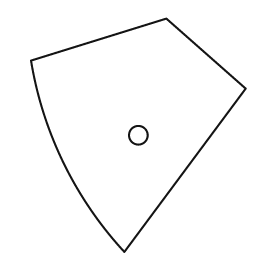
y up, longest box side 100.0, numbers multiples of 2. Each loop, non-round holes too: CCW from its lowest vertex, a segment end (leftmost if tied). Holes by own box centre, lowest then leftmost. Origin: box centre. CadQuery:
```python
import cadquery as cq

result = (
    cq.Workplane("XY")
    .moveTo(-6.0, -50.0)
    .lineTo(46.0, 20.0)
    .lineTo(12.0, 50.0)
    .lineTo(-46.0, 32.0)
    .threePointArc((-32.0, -12.0), (-6.0, -50.0))
    .close()
    .moveTo(0.0, 0.0)
    .circle(4.0)
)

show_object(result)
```